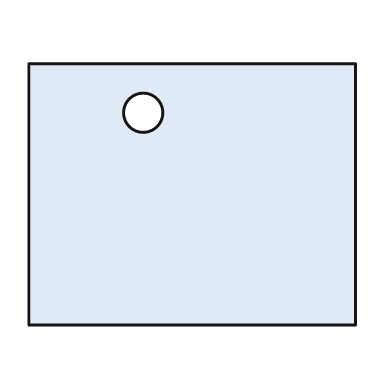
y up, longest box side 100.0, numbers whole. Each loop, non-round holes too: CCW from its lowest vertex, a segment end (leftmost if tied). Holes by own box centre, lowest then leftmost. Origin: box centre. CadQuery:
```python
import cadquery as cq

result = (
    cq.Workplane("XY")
    .moveTo(-50.0, -40.0)
    .lineTo(50.0, -40.0)
    .lineTo(50.0, 40.0)
    .lineTo(-50.0, 40.0)
    .close()
    .moveTo(-15.0, 25.0)
    .circle(6.0)
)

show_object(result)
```